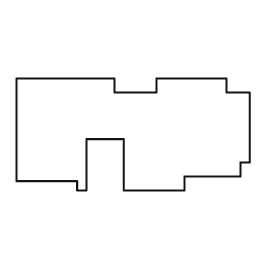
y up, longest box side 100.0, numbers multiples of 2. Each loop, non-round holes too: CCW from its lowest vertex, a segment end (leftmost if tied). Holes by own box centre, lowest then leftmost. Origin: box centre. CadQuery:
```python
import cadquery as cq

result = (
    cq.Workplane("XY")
    .moveTo(-24.0, -24.0)
    .lineTo(-20.0, -24.0)
    .lineTo(-20.0, -2.0)
    .lineTo(-4.0, -2.0)
    .lineTo(-4.0, -24.0)
    .lineTo(22.0, -24.0)
    .lineTo(22.0, -18.0)
    .lineTo(46.0, -18.0)
    .lineTo(46.0, -12.0)
    .lineTo(50.0, -12.0)
    .lineTo(50.0, 18.0)
    .lineTo(40.0, 18.0)
    .lineTo(40.0, 24.0)
    .lineTo(10.0, 24.0)
    .lineTo(10.0, 18.0)
    .lineTo(-8.0, 18.0)
    .lineTo(-8.0, 24.0)
    .lineTo(-50.0, 24.0)
    .lineTo(-50.0, -20.0)
    .lineTo(-24.0, -20.0)
    .close()
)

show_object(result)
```